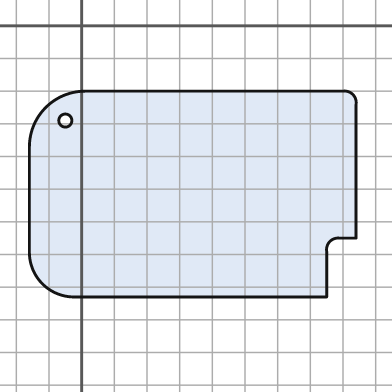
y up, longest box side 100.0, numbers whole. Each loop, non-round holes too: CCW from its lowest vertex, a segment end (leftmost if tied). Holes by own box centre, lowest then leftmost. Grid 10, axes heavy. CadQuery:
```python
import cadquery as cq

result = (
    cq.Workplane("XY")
    .moveTo(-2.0, -83.0)
    .lineTo(75.0, -83.0)
    .lineTo(75.0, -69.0)
    .threePointArc((76.0, -66.0), (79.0, -65.0))
    .lineTo(84.0, -65.0)
    .lineTo(84.0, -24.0)
    .threePointArc((83.0, -21.0), (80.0, -20.0))
    .lineTo(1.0, -20.0)
    .threePointArc((-11.0, -25.0), (-16.0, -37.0))
    .lineTo(-16.0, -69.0)
    .threePointArc((-12.0, -79.0), (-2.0, -83.0))
    .close()
    .moveTo(-5.0, -29.0)
    .circle(2.0)
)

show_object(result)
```